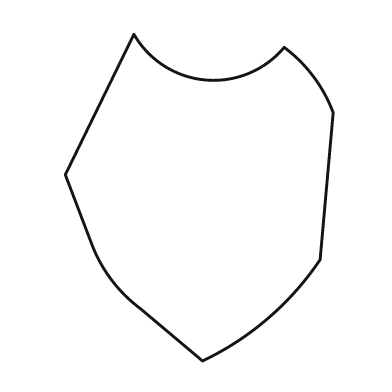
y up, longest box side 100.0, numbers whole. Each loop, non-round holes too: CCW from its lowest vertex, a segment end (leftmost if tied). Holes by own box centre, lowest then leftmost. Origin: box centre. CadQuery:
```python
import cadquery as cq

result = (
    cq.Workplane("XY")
    .moveTo(1.0, -50.0)
    .threePointArc((21.0, -37.0), (37.0, -19.0))
    .lineTo(41.0, 26.0)
    .threePointArc((35.0, 37.0), (26.0, 46.0))
    .threePointArc((2.0, 36.0), (-20.0, 50.0))
    .lineTo(-41.0, 7.0)
    .lineTo(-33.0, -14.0)
    .threePointArc((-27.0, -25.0), (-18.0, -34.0))
    .close()
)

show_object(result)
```